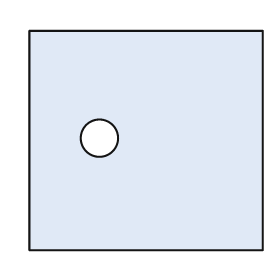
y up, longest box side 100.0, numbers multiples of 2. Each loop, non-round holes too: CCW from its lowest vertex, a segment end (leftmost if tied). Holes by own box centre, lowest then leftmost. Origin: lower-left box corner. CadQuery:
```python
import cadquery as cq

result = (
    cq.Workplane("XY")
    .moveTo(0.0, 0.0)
    .lineTo(100.0, 0.0)
    .lineTo(100.0, 94.0)
    .lineTo(0.0, 94.0)
    .close()
    .moveTo(30.0, 48.0)
    .circle(8.0)
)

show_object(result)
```